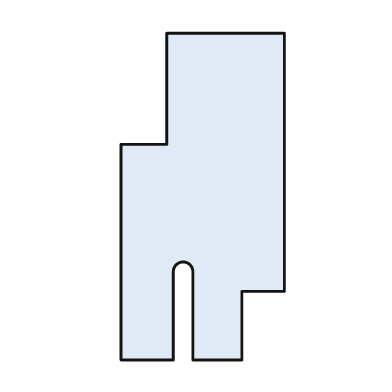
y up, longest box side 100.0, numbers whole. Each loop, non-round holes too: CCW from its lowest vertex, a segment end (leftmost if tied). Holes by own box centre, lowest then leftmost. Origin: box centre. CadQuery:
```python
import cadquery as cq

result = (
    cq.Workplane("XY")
    .moveTo(-25.0, -50.0)
    .lineTo(-9.0, -50.0)
    .lineTo(-9.0, -23.0)
    .threePointArc((-6.0, -20.0), (-3.0, -23.0))
    .lineTo(-3.0, -50.0)
    .lineTo(12.0, -50.0)
    .lineTo(12.0, -29.0)
    .lineTo(25.0, -29.0)
    .lineTo(25.0, 50.0)
    .lineTo(-11.0, 50.0)
    .lineTo(-11.0, 16.0)
    .lineTo(-25.0, 16.0)
    .close()
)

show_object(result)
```